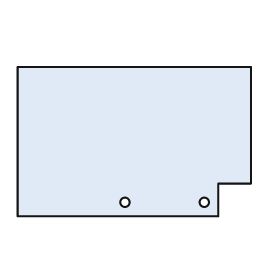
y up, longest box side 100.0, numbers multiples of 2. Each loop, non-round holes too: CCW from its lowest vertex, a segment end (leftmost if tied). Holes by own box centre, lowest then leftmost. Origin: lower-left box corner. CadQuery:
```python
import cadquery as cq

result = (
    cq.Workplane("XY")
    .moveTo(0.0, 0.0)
    .lineTo(86.0, 0.0)
    .lineTo(86.0, 14.0)
    .lineTo(100.0, 14.0)
    .lineTo(100.0, 64.0)
    .lineTo(0.0, 64.0)
    .close()
    .moveTo(46.0, 6.0)
    .circle(2.0)
    .moveTo(80.0, 6.0)
    .circle(2.0)
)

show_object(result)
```